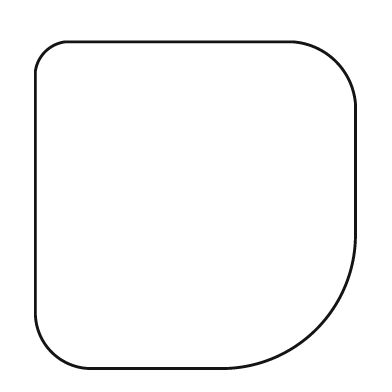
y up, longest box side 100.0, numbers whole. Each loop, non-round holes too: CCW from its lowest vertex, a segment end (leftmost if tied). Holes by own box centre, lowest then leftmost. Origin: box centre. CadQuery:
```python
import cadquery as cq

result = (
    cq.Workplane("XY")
    .moveTo(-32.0, -50.0)
    .lineTo(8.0, -50.0)
    .threePointArc((37.0, -38.0), (49.0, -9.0))
    .lineTo(49.0, 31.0)
    .threePointArc((43.0, 44.0), (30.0, 50.0))
    .lineTo(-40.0, 50.0)
    .threePointArc((-46.0, 47.0), (-49.0, 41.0))
    .lineTo(-49.0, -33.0)
    .threePointArc((-44.0, -45.0), (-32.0, -50.0))
    .close()
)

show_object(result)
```